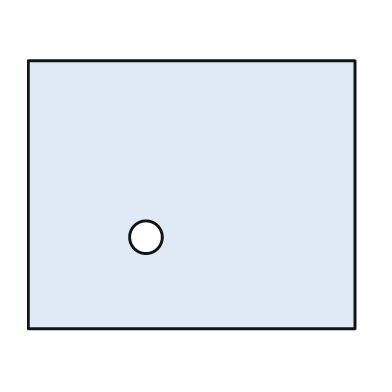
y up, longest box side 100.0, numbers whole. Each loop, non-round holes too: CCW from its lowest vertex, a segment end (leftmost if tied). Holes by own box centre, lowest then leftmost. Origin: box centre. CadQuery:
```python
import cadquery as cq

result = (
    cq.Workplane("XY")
    .moveTo(-50.0, -41.0)
    .lineTo(50.0, -41.0)
    .lineTo(50.0, 41.0)
    .lineTo(-50.0, 41.0)
    .close()
    .moveTo(-14.0, -13.0)
    .circle(5.0)
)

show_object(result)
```